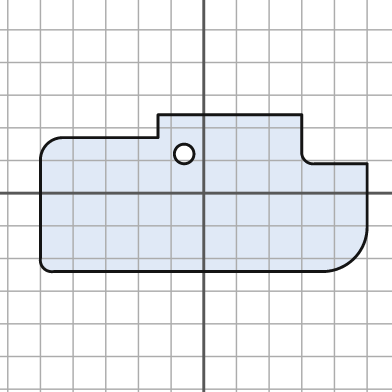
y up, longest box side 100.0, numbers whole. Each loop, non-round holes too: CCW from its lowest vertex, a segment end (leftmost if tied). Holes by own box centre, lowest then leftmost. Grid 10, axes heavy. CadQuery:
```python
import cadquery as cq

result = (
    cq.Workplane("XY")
    .moveTo(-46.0, -24.0)
    .lineTo(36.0, -24.0)
    .threePointArc((46.0, -20.0), (50.0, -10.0))
    .lineTo(50.0, 9.0)
    .lineTo(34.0, 9.0)
    .threePointArc((31.0, 10.0), (30.0, 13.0))
    .lineTo(30.0, 24.0)
    .lineTo(-14.0, 24.0)
    .lineTo(-14.0, 17.0)
    .lineTo(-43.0, 17.0)
    .threePointArc((-48.0, 15.0), (-50.0, 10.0))
    .lineTo(-50.0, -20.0)
    .threePointArc((-49.0, -23.0), (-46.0, -24.0))
    .close()
    .moveTo(-6.0, 12.0)
    .circle(3.0)
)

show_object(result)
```